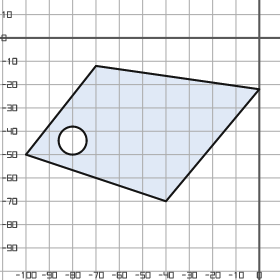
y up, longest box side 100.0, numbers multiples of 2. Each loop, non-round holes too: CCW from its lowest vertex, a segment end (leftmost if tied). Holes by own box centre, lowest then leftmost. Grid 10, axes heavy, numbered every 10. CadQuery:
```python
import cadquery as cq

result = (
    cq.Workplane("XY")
    .moveTo(-40.0, -70.0)
    .lineTo(0.0, -22.0)
    .lineTo(-70.0, -12.0)
    .lineTo(-100.0, -50.0)
    .close()
    .moveTo(-80.0, -44.0)
    .circle(6.0)
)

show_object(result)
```